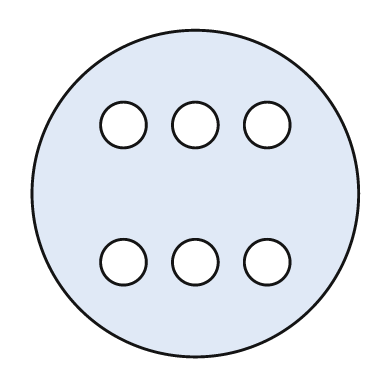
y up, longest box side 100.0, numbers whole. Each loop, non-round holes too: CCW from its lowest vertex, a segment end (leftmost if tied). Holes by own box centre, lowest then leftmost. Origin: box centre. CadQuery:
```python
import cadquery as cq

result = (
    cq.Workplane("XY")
    .moveTo(0.0, 0.0)
    .circle(50.0)
    .moveTo(-22.0, -21.0)
    .circle(7.0)
    .moveTo(0.0, -21.0)
    .circle(7.0)
    .moveTo(22.0, -21.0)
    .circle(7.0)
    .moveTo(-22.0, 21.0)
    .circle(7.0)
    .moveTo(0.0, 21.0)
    .circle(7.0)
    .moveTo(22.0, 21.0)
    .circle(7.0)
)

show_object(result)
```